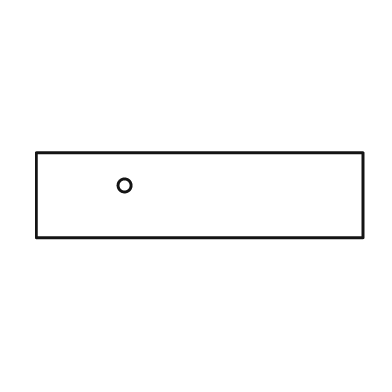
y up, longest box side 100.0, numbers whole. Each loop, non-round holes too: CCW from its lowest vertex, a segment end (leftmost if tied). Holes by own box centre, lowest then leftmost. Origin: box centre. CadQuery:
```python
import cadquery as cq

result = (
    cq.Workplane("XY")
    .moveTo(-50.0, -13.0)
    .lineTo(50.0, -13.0)
    .lineTo(50.0, 13.0)
    .lineTo(-50.0, 13.0)
    .close()
    .moveTo(-23.0, 3.0)
    .circle(2.0)
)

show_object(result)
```